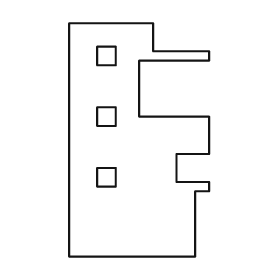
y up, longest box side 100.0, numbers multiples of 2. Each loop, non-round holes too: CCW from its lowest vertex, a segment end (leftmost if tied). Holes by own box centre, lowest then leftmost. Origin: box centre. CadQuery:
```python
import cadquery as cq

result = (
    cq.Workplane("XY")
    .moveTo(-30.0, -50.0)
    .lineTo(24.0, -50.0)
    .lineTo(24.0, -22.0)
    .lineTo(30.0, -22.0)
    .lineTo(30.0, -18.0)
    .lineTo(16.0, -18.0)
    .lineTo(16.0, -6.0)
    .lineTo(30.0, -6.0)
    .lineTo(30.0, 10.0)
    .lineTo(0.0, 10.0)
    .lineTo(0.0, 34.0)
    .lineTo(30.0, 34.0)
    .lineTo(30.0, 38.0)
    .lineTo(6.0, 38.0)
    .lineTo(6.0, 50.0)
    .lineTo(-30.0, 50.0)
    .close()
    .moveTo(-18.0, -20.0)
    .lineTo(-10.0, -20.0)
    .lineTo(-10.0, -12.0)
    .lineTo(-18.0, -12.0)
    .close()
    .moveTo(-18.0, 6.0)
    .lineTo(-10.0, 6.0)
    .lineTo(-10.0, 14.0)
    .lineTo(-18.0, 14.0)
    .close()
    .moveTo(-18.0, 32.0)
    .lineTo(-10.0, 32.0)
    .lineTo(-10.0, 40.0)
    .lineTo(-18.0, 40.0)
    .close()
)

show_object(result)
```